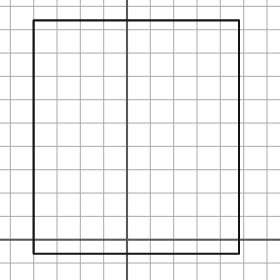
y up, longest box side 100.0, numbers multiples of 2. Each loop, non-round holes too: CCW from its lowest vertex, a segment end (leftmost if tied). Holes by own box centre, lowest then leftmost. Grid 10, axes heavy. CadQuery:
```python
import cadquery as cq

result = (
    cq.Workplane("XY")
    .moveTo(-40.0, -6.0)
    .lineTo(48.0, -6.0)
    .lineTo(48.0, 94.0)
    .lineTo(-40.0, 94.0)
    .close()
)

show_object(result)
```